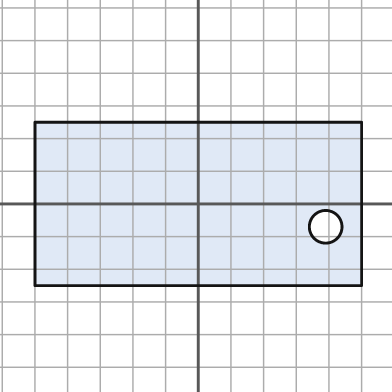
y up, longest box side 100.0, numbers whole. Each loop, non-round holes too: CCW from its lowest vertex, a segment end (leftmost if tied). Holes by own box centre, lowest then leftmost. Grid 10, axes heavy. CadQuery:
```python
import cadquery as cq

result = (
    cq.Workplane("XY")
    .moveTo(-50.0, -25.0)
    .lineTo(50.0, -25.0)
    .lineTo(50.0, 25.0)
    .lineTo(-50.0, 25.0)
    .close()
    .moveTo(39.0, -7.0)
    .circle(5.0)
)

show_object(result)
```